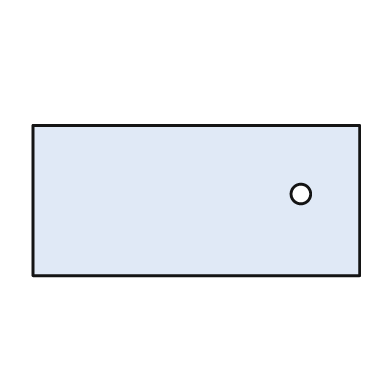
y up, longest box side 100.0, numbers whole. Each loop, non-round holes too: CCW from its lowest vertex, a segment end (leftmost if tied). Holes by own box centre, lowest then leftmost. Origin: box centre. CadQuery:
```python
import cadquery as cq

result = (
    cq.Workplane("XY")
    .moveTo(-50.0, -23.0)
    .lineTo(50.0, -23.0)
    .lineTo(50.0, 23.0)
    .lineTo(-50.0, 23.0)
    .close()
    .moveTo(32.0, 2.0)
    .circle(3.0)
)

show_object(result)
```